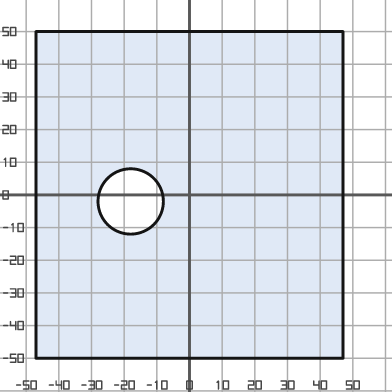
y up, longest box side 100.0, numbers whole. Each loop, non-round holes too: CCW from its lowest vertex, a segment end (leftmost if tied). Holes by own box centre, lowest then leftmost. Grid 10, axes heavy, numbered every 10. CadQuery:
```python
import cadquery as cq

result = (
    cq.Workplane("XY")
    .moveTo(-47.0, -50.0)
    .lineTo(47.0, -50.0)
    .lineTo(47.0, 50.0)
    .lineTo(-47.0, 50.0)
    .close()
    .moveTo(-18.0, -2.0)
    .circle(10.0)
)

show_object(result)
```